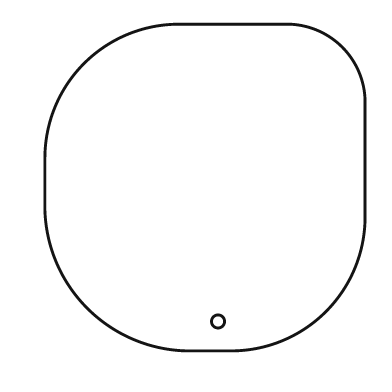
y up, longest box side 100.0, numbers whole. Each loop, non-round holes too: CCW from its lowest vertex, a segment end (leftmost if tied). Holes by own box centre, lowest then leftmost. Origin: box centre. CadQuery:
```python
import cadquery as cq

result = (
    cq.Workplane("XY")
    .moveTo(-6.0, -50.0)
    .lineTo(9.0, -50.0)
    .threePointArc((37.0, -38.0), (49.0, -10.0))
    .lineTo(49.0, 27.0)
    .threePointArc((42.0, 43.0), (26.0, 50.0))
    .lineTo(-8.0, 50.0)
    .threePointArc((-37.0, 38.0), (-49.0, 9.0))
    .lineTo(-49.0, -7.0)
    .threePointArc((-36.0, -37.0), (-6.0, -50.0))
    .close()
    .moveTo(4.0, -41.0)
    .circle(2.0)
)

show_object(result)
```